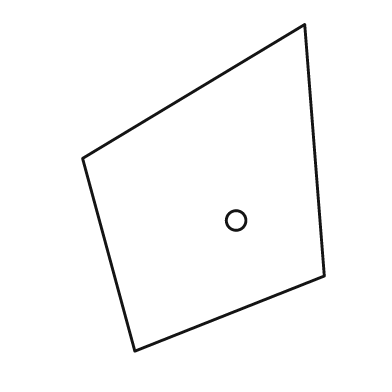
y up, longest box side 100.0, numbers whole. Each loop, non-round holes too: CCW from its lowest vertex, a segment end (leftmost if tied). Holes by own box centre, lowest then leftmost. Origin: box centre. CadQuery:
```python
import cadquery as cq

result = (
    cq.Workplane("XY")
    .moveTo(-21.0, -50.0)
    .lineTo(37.0, -27.0)
    .lineTo(31.0, 50.0)
    .lineTo(-37.0, 9.0)
    .close()
    .moveTo(10.0, -10.0)
    .circle(3.0)
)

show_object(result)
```